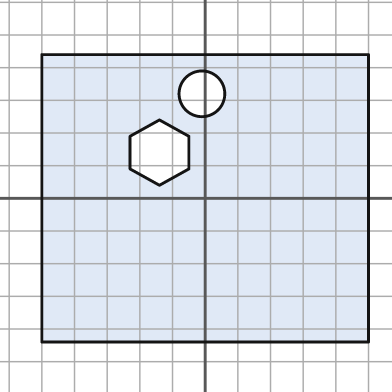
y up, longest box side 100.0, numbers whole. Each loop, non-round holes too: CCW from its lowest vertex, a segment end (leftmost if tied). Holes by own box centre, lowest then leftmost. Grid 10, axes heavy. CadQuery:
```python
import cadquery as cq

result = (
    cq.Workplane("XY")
    .moveTo(-50.0, -44.0)
    .lineTo(50.0, -44.0)
    .lineTo(50.0, 44.0)
    .lineTo(-50.0, 44.0)
    .close()
    .moveTo(-14.0, 4.0)
    .lineTo(-5.0, 9.0)
    .lineTo(-5.0, 19.0)
    .lineTo(-14.0, 24.0)
    .lineTo(-23.0, 19.0)
    .lineTo(-23.0, 9.0)
    .close()
    .moveTo(-1.0, 32.0)
    .circle(7.0)
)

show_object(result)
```